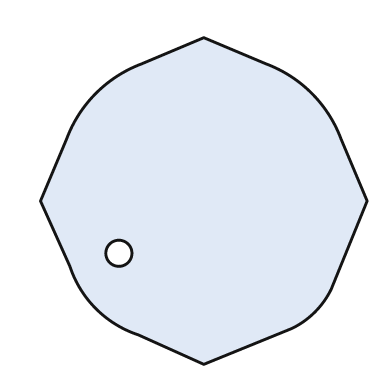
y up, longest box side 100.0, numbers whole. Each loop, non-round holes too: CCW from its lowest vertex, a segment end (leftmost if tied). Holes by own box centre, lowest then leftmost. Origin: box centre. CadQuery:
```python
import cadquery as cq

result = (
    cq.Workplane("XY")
    .moveTo(0.0, -50.0)
    .lineTo(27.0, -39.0)
    .threePointArc((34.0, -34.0), (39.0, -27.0))
    .lineTo(50.0, 0.0)
    .lineTo(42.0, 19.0)
    .threePointArc((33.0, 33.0), (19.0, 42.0))
    .lineTo(0.0, 50.0)
    .lineTo(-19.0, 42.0)
    .threePointArc((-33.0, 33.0), (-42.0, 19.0))
    .lineTo(-50.0, 0.0)
    .lineTo(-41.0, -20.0)
    .threePointArc((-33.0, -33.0), (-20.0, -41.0))
    .close()
    .moveTo(-26.0, -16.0)
    .circle(4.0)
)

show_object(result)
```